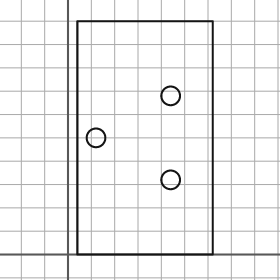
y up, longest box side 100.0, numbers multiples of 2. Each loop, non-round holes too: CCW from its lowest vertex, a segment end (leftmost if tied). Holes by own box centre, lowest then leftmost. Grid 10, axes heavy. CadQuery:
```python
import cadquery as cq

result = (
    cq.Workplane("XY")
    .moveTo(4.0, 0.0)
    .lineTo(62.0, 0.0)
    .lineTo(62.0, 100.0)
    .lineTo(4.0, 100.0)
    .close()
    .moveTo(44.0, 32.0)
    .circle(4.0)
    .moveTo(12.0, 50.0)
    .circle(4.0)
    .moveTo(44.0, 68.0)
    .circle(4.0)
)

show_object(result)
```